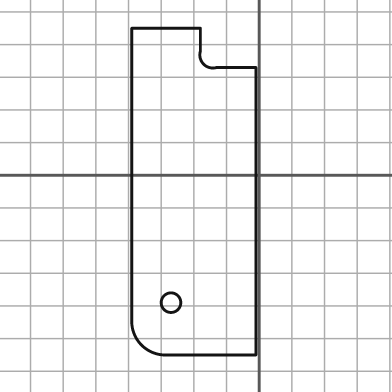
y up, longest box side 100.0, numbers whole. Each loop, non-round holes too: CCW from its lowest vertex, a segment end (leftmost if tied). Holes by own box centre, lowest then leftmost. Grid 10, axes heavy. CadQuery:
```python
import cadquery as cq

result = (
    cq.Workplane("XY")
    .moveTo(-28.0, -55.0)
    .lineTo(-1.0, -55.0)
    .lineTo(-1.0, 33.0)
    .lineTo(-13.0, 33.0)
    .threePointArc((-17.0, 34.0), (-18.0, 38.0))
    .lineTo(-18.0, 45.0)
    .lineTo(-39.0, 45.0)
    .lineTo(-39.0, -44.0)
    .threePointArc((-36.0, -52.0), (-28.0, -55.0))
    .close()
    .moveTo(-27.0, -39.0)
    .circle(3.0)
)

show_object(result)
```